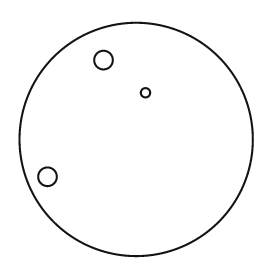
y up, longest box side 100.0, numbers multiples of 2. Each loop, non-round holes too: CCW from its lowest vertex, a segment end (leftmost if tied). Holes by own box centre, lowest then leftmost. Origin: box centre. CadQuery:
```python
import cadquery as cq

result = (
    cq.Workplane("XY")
    .moveTo(0.0, 0.0)
    .circle(50.0)
    .moveTo(-38.0, -16.0)
    .circle(4.0)
    .moveTo(4.0, 20.0)
    .circle(2.0)
    .moveTo(-14.0, 34.0)
    .circle(4.0)
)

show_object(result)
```